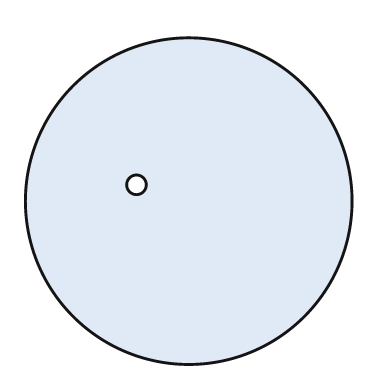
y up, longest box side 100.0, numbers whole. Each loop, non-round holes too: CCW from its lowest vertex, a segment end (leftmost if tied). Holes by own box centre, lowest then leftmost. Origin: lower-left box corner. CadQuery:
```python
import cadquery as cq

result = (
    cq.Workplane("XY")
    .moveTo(50.0, 50.0)
    .circle(50.0)
    .moveTo(34.0, 55.0)
    .circle(3.0)
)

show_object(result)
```